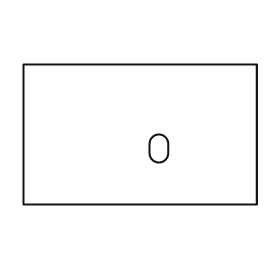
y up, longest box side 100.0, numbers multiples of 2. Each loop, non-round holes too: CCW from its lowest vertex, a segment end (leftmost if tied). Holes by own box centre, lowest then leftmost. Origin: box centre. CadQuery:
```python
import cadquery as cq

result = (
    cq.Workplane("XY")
    .moveTo(-50.0, -30.0)
    .lineTo(50.0, -30.0)
    .lineTo(50.0, 30.0)
    .lineTo(-50.0, 30.0)
    .close()
    .moveTo(4.0, -8.0)
    .threePointArc((8.0, -12.0), (12.0, -8.0))
    .lineTo(12.0, -4.0)
    .threePointArc((8.0, 0.0), (4.0, -4.0))
    .close()
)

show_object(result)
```